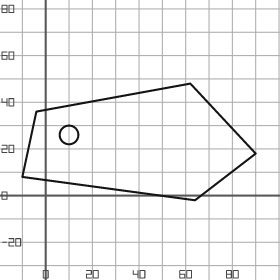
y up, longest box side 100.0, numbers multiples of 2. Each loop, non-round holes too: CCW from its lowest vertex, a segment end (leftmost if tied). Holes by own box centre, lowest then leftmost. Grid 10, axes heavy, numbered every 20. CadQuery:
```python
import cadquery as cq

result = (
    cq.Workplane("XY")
    .moveTo(64.0, -2.0)
    .lineTo(90.0, 18.0)
    .lineTo(62.0, 48.0)
    .lineTo(-4.0, 36.0)
    .lineTo(-10.0, 8.0)
    .close()
    .moveTo(10.0, 26.0)
    .circle(4.0)
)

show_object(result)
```